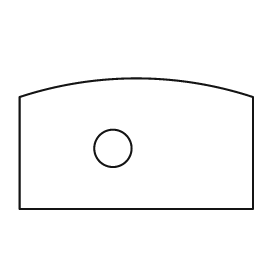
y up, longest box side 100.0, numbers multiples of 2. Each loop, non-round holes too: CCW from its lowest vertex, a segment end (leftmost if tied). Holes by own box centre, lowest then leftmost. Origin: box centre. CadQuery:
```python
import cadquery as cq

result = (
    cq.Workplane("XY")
    .moveTo(-50.0, -28.0)
    .lineTo(50.0, -28.0)
    .lineTo(50.0, 20.0)
    .threePointArc((0.0, 28.0), (-50.0, 20.0))
    .close()
    .moveTo(-10.0, -2.0)
    .circle(8.0)
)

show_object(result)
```